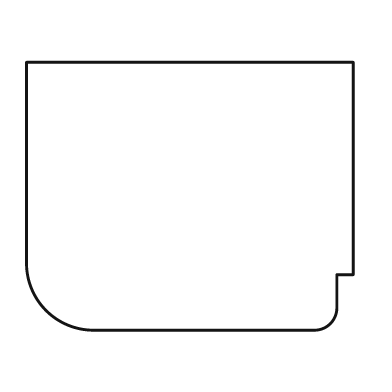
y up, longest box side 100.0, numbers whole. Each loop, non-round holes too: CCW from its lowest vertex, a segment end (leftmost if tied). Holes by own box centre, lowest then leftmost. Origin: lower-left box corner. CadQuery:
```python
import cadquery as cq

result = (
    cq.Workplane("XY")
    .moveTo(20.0, 0.0)
    .lineTo(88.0, 0.0)
    .threePointArc((93.0, 2.0), (95.0, 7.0))
    .lineTo(95.0, 17.0)
    .lineTo(100.0, 17.0)
    .lineTo(100.0, 82.0)
    .lineTo(0.0, 82.0)
    .lineTo(0.0, 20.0)
    .threePointArc((6.0, 6.0), (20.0, 0.0))
    .close()
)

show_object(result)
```